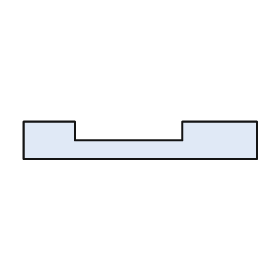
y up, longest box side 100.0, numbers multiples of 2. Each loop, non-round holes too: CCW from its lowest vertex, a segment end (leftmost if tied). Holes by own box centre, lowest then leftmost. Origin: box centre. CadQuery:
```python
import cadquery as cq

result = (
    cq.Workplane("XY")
    .moveTo(-50.0, -8.0)
    .lineTo(50.0, -8.0)
    .lineTo(50.0, 8.0)
    .lineTo(18.0, 8.0)
    .lineTo(18.0, 0.0)
    .lineTo(-28.0, 0.0)
    .lineTo(-28.0, 8.0)
    .lineTo(-50.0, 8.0)
    .close()
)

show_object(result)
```